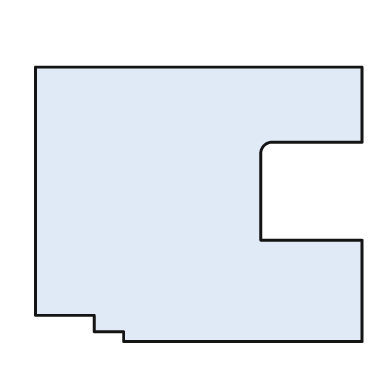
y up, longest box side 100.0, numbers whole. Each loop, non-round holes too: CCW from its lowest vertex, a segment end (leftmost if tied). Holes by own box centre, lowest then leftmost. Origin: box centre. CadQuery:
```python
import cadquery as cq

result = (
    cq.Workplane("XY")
    .moveTo(-23.0, -42.0)
    .lineTo(50.0, -42.0)
    .lineTo(50.0, -11.0)
    .lineTo(19.0, -11.0)
    .lineTo(19.0, 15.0)
    .threePointArc((20.0, 18.0), (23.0, 19.0))
    .lineTo(50.0, 19.0)
    .lineTo(50.0, 42.0)
    .lineTo(-50.0, 42.0)
    .lineTo(-50.0, -34.0)
    .lineTo(-32.0, -34.0)
    .lineTo(-32.0, -39.0)
    .lineTo(-23.0, -39.0)
    .close()
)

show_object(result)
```